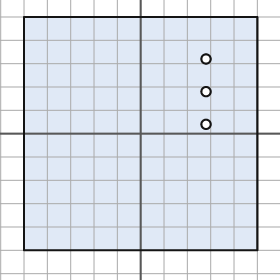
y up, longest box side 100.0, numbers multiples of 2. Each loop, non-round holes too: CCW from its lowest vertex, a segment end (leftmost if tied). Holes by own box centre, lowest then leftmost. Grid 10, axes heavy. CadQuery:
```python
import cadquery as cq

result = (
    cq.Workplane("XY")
    .moveTo(-50.0, -50.0)
    .lineTo(50.0, -50.0)
    .lineTo(50.0, 50.0)
    .lineTo(-50.0, 50.0)
    .close()
    .moveTo(28.0, 4.0)
    .circle(2.0)
    .moveTo(28.0, 18.0)
    .circle(2.0)
    .moveTo(28.0, 32.0)
    .circle(2.0)
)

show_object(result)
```